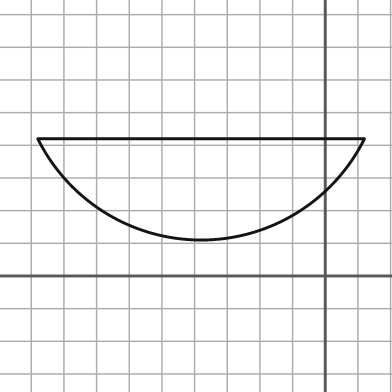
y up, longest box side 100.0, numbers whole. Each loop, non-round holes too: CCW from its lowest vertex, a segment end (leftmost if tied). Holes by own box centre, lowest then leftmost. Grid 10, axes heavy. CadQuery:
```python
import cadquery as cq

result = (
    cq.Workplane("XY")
    .moveTo(-88.0, 42.0)
    .threePointArc((-38.0, 11.0), (12.0, 42.0))
    .close()
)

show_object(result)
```